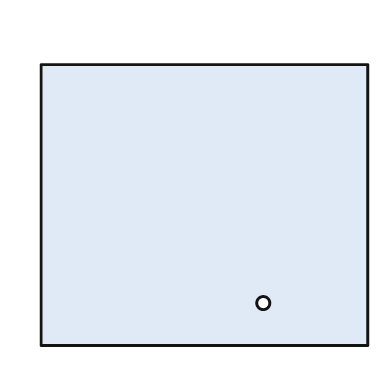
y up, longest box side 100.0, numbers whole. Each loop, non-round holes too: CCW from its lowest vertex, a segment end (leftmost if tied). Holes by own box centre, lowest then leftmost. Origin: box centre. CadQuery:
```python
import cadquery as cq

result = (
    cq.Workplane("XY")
    .moveTo(-50.0, -43.0)
    .lineTo(50.0, -43.0)
    .lineTo(50.0, 43.0)
    .lineTo(-50.0, 43.0)
    .close()
    .moveTo(18.0, -30.0)
    .circle(2.0)
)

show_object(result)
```